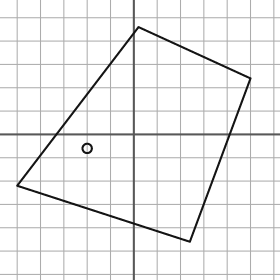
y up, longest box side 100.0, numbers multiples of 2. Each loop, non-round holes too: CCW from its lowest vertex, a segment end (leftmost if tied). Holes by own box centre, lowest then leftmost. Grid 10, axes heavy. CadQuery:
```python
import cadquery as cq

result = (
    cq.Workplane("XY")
    .moveTo(24.0, -46.0)
    .lineTo(50.0, 24.0)
    .lineTo(2.0, 46.0)
    .lineTo(-50.0, -22.0)
    .close()
    .moveTo(-20.0, -6.0)
    .circle(2.0)
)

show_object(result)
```